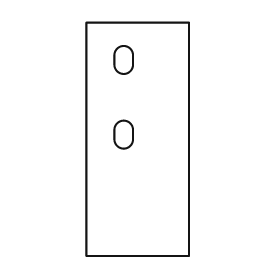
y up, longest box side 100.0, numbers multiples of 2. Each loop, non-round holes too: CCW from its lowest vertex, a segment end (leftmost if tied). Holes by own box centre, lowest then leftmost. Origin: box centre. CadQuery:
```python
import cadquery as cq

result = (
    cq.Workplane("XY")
    .moveTo(-22.0, -50.0)
    .lineTo(22.0, -50.0)
    .lineTo(22.0, 50.0)
    .lineTo(-22.0, 50.0)
    .close()
    .moveTo(-10.0, 0.0)
    .threePointArc((-6.0, -4.0), (-2.0, 0.0))
    .lineTo(-2.0, 4.0)
    .threePointArc((-6.0, 8.0), (-10.0, 4.0))
    .close()
    .moveTo(-10.0, 32.0)
    .threePointArc((-6.0, 28.0), (-2.0, 32.0))
    .lineTo(-2.0, 36.0)
    .threePointArc((-6.0, 40.0), (-10.0, 36.0))
    .close()
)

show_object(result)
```